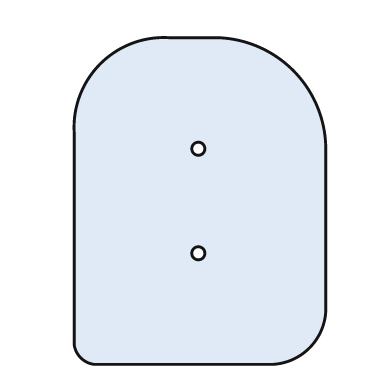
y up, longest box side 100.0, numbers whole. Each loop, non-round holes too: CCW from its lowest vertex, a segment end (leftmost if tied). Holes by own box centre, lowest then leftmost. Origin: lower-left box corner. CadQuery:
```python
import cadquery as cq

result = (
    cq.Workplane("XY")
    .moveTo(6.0, 0.0)
    .lineTo(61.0, 0.0)
    .threePointArc((72.0, 5.0), (77.0, 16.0))
    .lineTo(77.0, 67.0)
    .threePointArc((67.0, 90.0), (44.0, 100.0))
    .lineTo(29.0, 100.0)
    .threePointArc((8.0, 92.0), (0.0, 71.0))
    .lineTo(0.0, 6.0)
    .threePointArc((2.0, 2.0), (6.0, 0.0))
    .close()
    .moveTo(38.0, 34.0)
    .circle(2.0)
    .moveTo(38.0, 66.0)
    .circle(2.0)
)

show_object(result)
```